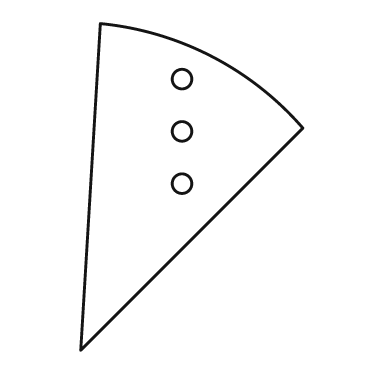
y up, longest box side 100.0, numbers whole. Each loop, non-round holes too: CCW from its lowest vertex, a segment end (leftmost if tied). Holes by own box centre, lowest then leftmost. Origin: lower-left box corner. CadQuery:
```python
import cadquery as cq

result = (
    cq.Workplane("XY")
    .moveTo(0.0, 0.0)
    .lineTo(68.0, 68.0)
    .threePointArc((40.0, 90.0), (6.0, 100.0))
    .close()
    .moveTo(31.0, 51.0)
    .circle(3.0)
    .moveTo(31.0, 67.0)
    .circle(3.0)
    .moveTo(31.0, 83.0)
    .circle(3.0)
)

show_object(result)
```